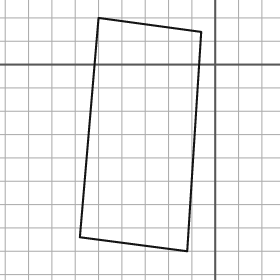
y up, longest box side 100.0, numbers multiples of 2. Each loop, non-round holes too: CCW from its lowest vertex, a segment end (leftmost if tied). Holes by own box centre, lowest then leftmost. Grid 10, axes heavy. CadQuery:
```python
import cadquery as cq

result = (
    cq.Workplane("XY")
    .moveTo(-12.0, -80.0)
    .lineTo(-6.0, 14.0)
    .lineTo(-50.0, 20.0)
    .lineTo(-58.0, -74.0)
    .close()
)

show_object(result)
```